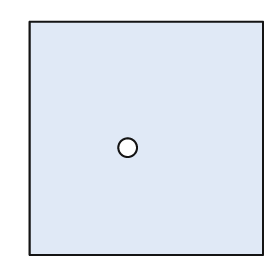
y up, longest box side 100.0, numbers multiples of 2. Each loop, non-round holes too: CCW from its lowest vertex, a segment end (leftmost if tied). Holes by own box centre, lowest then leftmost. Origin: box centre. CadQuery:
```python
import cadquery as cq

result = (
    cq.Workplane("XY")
    .moveTo(-50.0, -50.0)
    .lineTo(50.0, -50.0)
    .lineTo(50.0, 50.0)
    .lineTo(-50.0, 50.0)
    .close()
    .moveTo(-8.0, -4.0)
    .circle(4.0)
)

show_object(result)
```